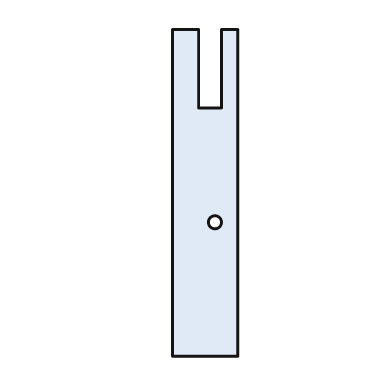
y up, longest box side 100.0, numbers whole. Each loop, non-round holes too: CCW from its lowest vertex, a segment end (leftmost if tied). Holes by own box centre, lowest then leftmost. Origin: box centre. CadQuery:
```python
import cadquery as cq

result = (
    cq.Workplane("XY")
    .moveTo(-10.0, -50.0)
    .lineTo(10.0, -50.0)
    .lineTo(10.0, 50.0)
    .lineTo(5.0, 50.0)
    .lineTo(5.0, 26.0)
    .lineTo(-2.0, 26.0)
    .lineTo(-2.0, 50.0)
    .lineTo(-10.0, 50.0)
    .close()
    .moveTo(3.0, -9.0)
    .circle(2.0)
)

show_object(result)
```